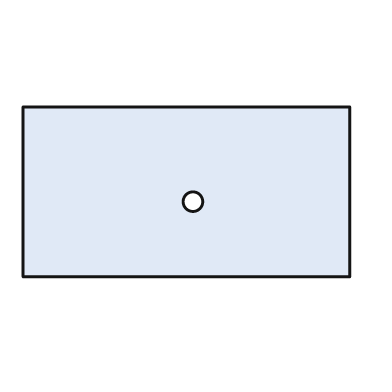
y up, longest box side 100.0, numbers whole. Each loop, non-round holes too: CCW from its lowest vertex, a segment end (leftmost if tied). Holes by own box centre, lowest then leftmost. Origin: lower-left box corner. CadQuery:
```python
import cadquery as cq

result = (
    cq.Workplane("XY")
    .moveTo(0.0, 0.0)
    .lineTo(100.0, 0.0)
    .lineTo(100.0, 52.0)
    .lineTo(0.0, 52.0)
    .close()
    .moveTo(52.0, 23.0)
    .circle(3.0)
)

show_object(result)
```